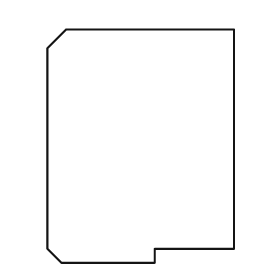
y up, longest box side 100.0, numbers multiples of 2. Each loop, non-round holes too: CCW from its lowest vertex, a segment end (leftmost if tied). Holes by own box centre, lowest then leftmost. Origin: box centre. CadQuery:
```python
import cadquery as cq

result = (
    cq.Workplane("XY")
    .moveTo(-34.0, -50.0)
    .lineTo(6.0, -50.0)
    .lineTo(6.0, -44.0)
    .lineTo(40.0, -44.0)
    .lineTo(40.0, 50.0)
    .lineTo(-32.0, 50.0)
    .lineTo(-40.0, 42.0)
    .lineTo(-40.0, -44.0)
    .close()
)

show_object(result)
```